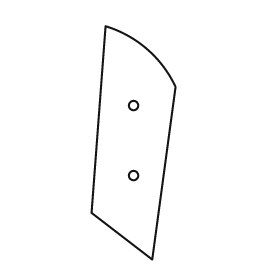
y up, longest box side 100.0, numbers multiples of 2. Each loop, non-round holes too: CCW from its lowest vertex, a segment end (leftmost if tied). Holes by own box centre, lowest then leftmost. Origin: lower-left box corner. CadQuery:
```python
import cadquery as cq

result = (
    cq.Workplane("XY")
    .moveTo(26.0, 0.0)
    .lineTo(36.0, 74.0)
    .threePointArc((24.0, 90.0), (6.0, 100.0))
    .lineTo(0.0, 20.0)
    .close()
    .moveTo(18.0, 36.0)
    .circle(2.0)
    .moveTo(18.0, 66.0)
    .circle(2.0)
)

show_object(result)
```